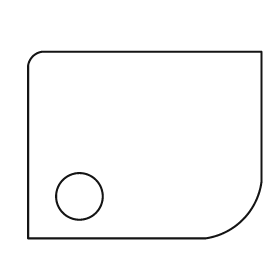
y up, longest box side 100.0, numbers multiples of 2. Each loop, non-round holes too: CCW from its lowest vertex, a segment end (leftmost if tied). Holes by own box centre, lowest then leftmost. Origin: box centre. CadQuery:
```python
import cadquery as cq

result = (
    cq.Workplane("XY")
    .moveTo(-50.0, -40.0)
    .lineTo(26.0, -40.0)
    .threePointArc((42.0, -32.0), (50.0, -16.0))
    .lineTo(50.0, 40.0)
    .lineTo(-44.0, 40.0)
    .threePointArc((-48.0, 38.0), (-50.0, 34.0))
    .close()
    .moveTo(-28.0, -22.0)
    .circle(10.0)
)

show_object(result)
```